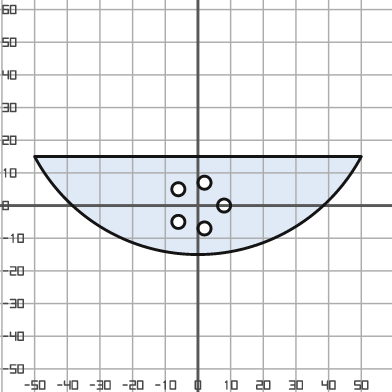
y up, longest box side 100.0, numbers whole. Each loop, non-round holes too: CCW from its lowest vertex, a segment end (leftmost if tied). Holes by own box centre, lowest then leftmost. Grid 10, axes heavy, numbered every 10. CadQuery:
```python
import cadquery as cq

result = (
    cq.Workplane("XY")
    .moveTo(-50.0, 15.0)
    .threePointArc((0.0, -15.0), (50.0, 15.0))
    .close()
    .moveTo(2.0, -7.0)
    .circle(2.0)
    .moveTo(-6.0, -5.0)
    .circle(2.0)
    .moveTo(8.0, 0.0)
    .circle(2.0)
    .moveTo(-6.0, 5.0)
    .circle(2.0)
    .moveTo(2.0, 7.0)
    .circle(2.0)
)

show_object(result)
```